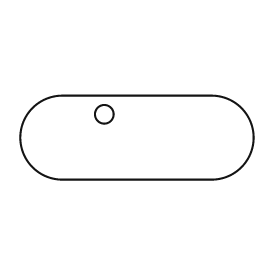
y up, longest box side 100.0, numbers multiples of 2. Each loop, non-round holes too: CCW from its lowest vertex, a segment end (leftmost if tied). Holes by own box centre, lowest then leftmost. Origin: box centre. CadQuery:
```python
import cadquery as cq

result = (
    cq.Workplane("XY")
    .moveTo(-32.0, -18.0)
    .lineTo(32.0, -18.0)
    .threePointArc((50.0, 0.0), (32.0, 18.0))
    .lineTo(-32.0, 18.0)
    .threePointArc((-50.0, 0.0), (-32.0, -18.0))
    .close()
    .moveTo(-14.0, 10.0)
    .circle(4.0)
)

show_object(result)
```